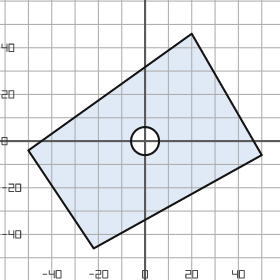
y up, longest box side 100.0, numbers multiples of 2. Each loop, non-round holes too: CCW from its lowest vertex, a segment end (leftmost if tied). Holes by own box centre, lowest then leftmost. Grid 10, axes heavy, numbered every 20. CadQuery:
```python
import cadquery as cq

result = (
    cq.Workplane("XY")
    .moveTo(-22.0, -46.0)
    .lineTo(50.0, -6.0)
    .lineTo(20.0, 46.0)
    .lineTo(-50.0, -4.0)
    .close()
    .moveTo(0.0, 0.0)
    .circle(6.0)
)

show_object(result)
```